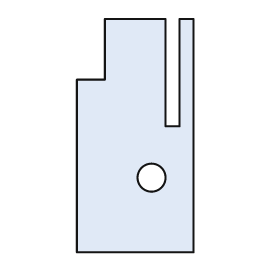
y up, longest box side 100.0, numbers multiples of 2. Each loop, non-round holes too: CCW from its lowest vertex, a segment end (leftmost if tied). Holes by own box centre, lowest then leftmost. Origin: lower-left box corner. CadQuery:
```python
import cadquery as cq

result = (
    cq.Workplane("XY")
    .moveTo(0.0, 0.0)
    .lineTo(50.0, 0.0)
    .lineTo(50.0, 100.0)
    .lineTo(44.0, 100.0)
    .lineTo(44.0, 54.0)
    .lineTo(38.0, 54.0)
    .lineTo(38.0, 100.0)
    .lineTo(12.0, 100.0)
    .lineTo(12.0, 74.0)
    .lineTo(0.0, 74.0)
    .close()
    .moveTo(32.0, 32.0)
    .circle(6.0)
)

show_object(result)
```